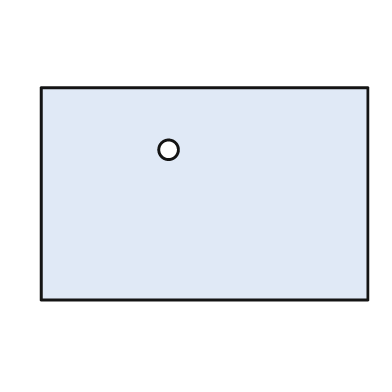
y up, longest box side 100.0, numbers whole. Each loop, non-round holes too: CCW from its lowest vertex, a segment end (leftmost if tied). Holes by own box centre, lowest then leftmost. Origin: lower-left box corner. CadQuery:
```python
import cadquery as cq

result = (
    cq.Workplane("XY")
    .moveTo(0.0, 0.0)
    .lineTo(100.0, 0.0)
    .lineTo(100.0, 65.0)
    .lineTo(0.0, 65.0)
    .close()
    .moveTo(39.0, 46.0)
    .circle(3.0)
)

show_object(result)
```